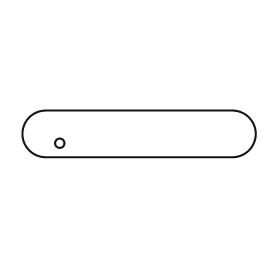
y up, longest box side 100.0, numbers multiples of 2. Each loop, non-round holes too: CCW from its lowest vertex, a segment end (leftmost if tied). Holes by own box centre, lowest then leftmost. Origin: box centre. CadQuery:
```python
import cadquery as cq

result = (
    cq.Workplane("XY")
    .moveTo(-40.0, -10.0)
    .lineTo(40.0, -10.0)
    .threePointArc((50.0, 0.0), (40.0, 10.0))
    .lineTo(-40.0, 10.0)
    .threePointArc((-50.0, 0.0), (-40.0, -10.0))
    .close()
    .moveTo(-34.0, -4.0)
    .circle(2.0)
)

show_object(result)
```